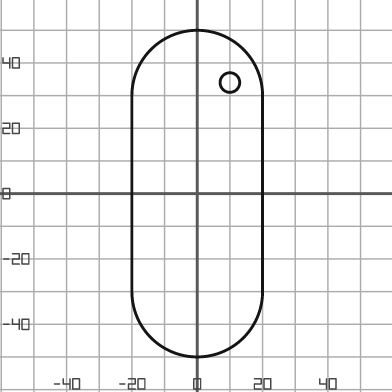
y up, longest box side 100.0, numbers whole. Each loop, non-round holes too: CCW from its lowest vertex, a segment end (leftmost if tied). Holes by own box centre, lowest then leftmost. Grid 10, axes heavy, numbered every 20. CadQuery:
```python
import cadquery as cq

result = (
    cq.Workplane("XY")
    .moveTo(-20.0, -30.0)
    .threePointArc((0.0, -50.0), (20.0, -30.0))
    .lineTo(20.0, 30.0)
    .threePointArc((0.0, 50.0), (-20.0, 30.0))
    .close()
    .moveTo(10.0, 34.0)
    .circle(3.0)
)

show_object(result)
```